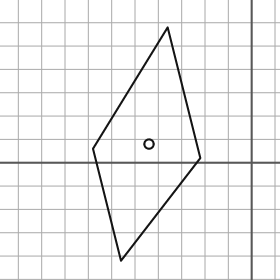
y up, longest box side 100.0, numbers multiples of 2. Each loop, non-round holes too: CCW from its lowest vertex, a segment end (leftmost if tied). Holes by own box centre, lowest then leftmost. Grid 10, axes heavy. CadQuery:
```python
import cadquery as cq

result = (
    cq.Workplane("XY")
    .moveTo(-56.0, -42.0)
    .lineTo(-22.0, 2.0)
    .lineTo(-36.0, 58.0)
    .lineTo(-68.0, 6.0)
    .close()
    .moveTo(-44.0, 8.0)
    .circle(2.0)
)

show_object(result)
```